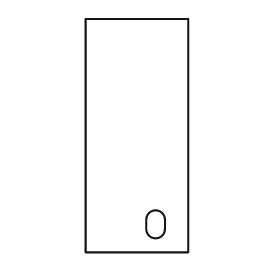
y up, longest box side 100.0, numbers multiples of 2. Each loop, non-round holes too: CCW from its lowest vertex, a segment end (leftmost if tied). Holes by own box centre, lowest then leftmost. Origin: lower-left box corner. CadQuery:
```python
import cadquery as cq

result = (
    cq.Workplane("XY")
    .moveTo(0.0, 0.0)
    .lineTo(44.0, 0.0)
    .lineTo(44.0, 100.0)
    .lineTo(0.0, 100.0)
    .close()
    .moveTo(26.0, 10.0)
    .threePointArc((30.0, 6.0), (34.0, 10.0))
    .lineTo(34.0, 14.0)
    .threePointArc((30.0, 18.0), (26.0, 14.0))
    .close()
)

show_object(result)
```